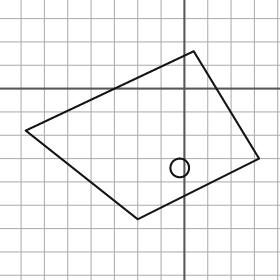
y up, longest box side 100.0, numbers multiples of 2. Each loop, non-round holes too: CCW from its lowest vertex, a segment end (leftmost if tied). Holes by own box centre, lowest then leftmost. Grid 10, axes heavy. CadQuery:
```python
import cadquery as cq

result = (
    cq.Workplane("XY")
    .moveTo(-20.0, -56.0)
    .lineTo(32.0, -30.0)
    .lineTo(4.0, 16.0)
    .lineTo(-68.0, -18.0)
    .close()
    .moveTo(-2.0, -34.0)
    .circle(4.0)
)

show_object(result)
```